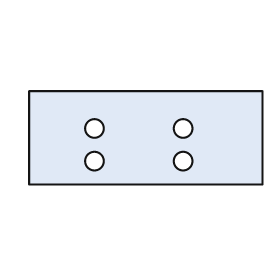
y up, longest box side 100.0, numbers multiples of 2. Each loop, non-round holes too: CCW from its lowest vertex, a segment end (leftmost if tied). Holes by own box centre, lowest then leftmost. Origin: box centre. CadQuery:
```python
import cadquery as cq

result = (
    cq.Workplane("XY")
    .moveTo(-50.0, -20.0)
    .lineTo(50.0, -20.0)
    .lineTo(50.0, 20.0)
    .lineTo(-50.0, 20.0)
    .close()
    .moveTo(-22.0, -10.0)
    .circle(4.0)
    .moveTo(16.0, -10.0)
    .circle(4.0)
    .moveTo(-22.0, 4.0)
    .circle(4.0)
    .moveTo(16.0, 4.0)
    .circle(4.0)
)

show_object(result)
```